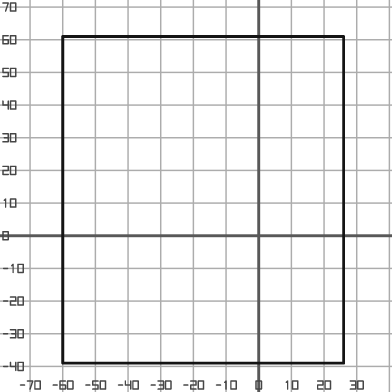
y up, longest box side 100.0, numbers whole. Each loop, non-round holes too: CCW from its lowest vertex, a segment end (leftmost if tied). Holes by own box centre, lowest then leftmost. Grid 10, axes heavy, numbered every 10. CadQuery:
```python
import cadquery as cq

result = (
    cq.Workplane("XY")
    .moveTo(-60.0, -39.0)
    .lineTo(26.0, -39.0)
    .lineTo(26.0, 61.0)
    .lineTo(-60.0, 61.0)
    .close()
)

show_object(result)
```